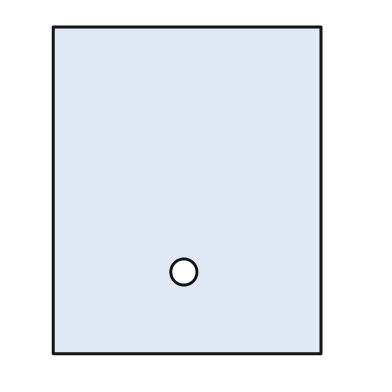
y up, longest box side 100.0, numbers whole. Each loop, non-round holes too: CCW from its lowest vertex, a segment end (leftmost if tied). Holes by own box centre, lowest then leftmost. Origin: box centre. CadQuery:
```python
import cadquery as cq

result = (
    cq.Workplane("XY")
    .moveTo(-41.0, -50.0)
    .lineTo(41.0, -50.0)
    .lineTo(41.0, 50.0)
    .lineTo(-41.0, 50.0)
    .close()
    .moveTo(-1.0, -25.0)
    .circle(4.0)
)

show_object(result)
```